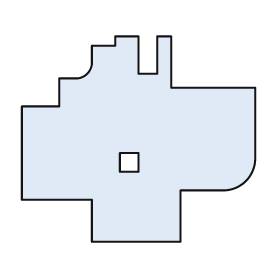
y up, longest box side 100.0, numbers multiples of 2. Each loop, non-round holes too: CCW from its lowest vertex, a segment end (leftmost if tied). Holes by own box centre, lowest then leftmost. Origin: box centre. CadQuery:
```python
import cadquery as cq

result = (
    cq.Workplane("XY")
    .moveTo(-20.0, -44.0)
    .lineTo(18.0, -44.0)
    .lineTo(18.0, -22.0)
    .lineTo(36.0, -22.0)
    .threePointArc((46.0, -18.0), (50.0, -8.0))
    .lineTo(50.0, 22.0)
    .lineTo(14.0, 22.0)
    .lineTo(14.0, 44.0)
    .lineTo(8.0, 44.0)
    .lineTo(8.0, 28.0)
    .lineTo(0.0, 28.0)
    .lineTo(0.0, 44.0)
    .lineTo(-10.0, 44.0)
    .lineTo(-10.0, 40.0)
    .lineTo(-20.0, 40.0)
    .lineTo(-20.0, 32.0)
    .threePointArc((-22.0, 28.0), (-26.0, 26.0))
    .lineTo(-34.0, 26.0)
    .lineTo(-34.0, 14.0)
    .lineTo(-50.0, 14.0)
    .lineTo(-50.0, -26.0)
    .lineTo(-20.0, -26.0)
    .close()
    .moveTo(-8.0, -14.0)
    .lineTo(0.0, -14.0)
    .lineTo(0.0, -6.0)
    .lineTo(-8.0, -6.0)
    .close()
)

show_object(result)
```